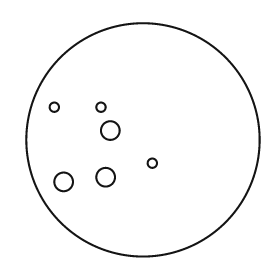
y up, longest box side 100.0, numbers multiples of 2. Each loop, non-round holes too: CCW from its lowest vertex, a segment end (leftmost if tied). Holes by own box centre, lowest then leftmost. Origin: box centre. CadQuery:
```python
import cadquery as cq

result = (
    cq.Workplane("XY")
    .moveTo(0.0, 0.0)
    .circle(50.0)
    .moveTo(-34.0, -18.0)
    .circle(4.0)
    .moveTo(-16.0, -16.0)
    .circle(4.0)
    .moveTo(4.0, -10.0)
    .circle(2.0)
    .moveTo(-14.0, 4.0)
    .circle(4.0)
    .moveTo(-38.0, 14.0)
    .circle(2.0)
    .moveTo(-18.0, 14.0)
    .circle(2.0)
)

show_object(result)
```